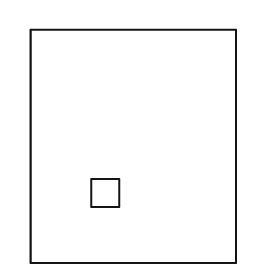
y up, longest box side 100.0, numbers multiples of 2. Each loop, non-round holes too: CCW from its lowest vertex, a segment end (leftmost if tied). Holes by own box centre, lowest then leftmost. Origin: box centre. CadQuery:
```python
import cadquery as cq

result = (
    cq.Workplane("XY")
    .moveTo(-44.0, -50.0)
    .lineTo(44.0, -50.0)
    .lineTo(44.0, 50.0)
    .lineTo(-44.0, 50.0)
    .close()
    .moveTo(-18.0, -26.0)
    .lineTo(-6.0, -26.0)
    .lineTo(-6.0, -14.0)
    .lineTo(-18.0, -14.0)
    .close()
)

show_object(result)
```